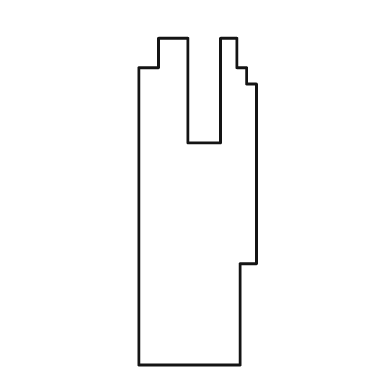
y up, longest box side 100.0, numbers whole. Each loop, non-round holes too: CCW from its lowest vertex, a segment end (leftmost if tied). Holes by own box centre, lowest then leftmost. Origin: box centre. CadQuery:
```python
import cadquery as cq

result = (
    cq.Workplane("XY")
    .moveTo(-18.0, -50.0)
    .lineTo(13.0, -50.0)
    .lineTo(13.0, -19.0)
    .lineTo(18.0, -19.0)
    .lineTo(18.0, 36.0)
    .lineTo(15.0, 36.0)
    .lineTo(15.0, 41.0)
    .lineTo(12.0, 41.0)
    .lineTo(12.0, 50.0)
    .lineTo(7.0, 50.0)
    .lineTo(7.0, 18.0)
    .lineTo(-3.0, 18.0)
    .lineTo(-3.0, 50.0)
    .lineTo(-12.0, 50.0)
    .lineTo(-12.0, 41.0)
    .lineTo(-18.0, 41.0)
    .close()
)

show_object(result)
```